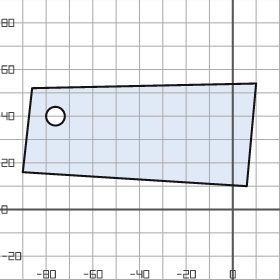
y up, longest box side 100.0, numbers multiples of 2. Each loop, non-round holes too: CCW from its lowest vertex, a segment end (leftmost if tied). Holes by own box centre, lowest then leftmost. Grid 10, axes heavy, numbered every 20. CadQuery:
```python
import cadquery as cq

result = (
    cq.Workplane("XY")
    .moveTo(6.0, 10.0)
    .lineTo(10.0, 54.0)
    .lineTo(-86.0, 52.0)
    .lineTo(-90.0, 16.0)
    .close()
    .moveTo(-76.0, 40.0)
    .circle(4.0)
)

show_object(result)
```